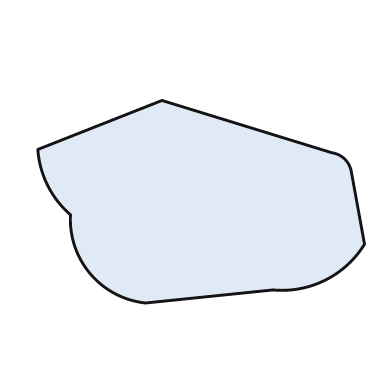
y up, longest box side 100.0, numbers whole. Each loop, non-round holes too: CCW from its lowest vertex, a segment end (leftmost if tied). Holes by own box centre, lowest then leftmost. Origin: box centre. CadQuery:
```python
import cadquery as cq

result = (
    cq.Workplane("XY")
    .moveTo(-17.0, -31.0)
    .lineTo(22.0, -27.0)
    .threePointArc((38.0, -24.0), (50.0, -13.0))
    .lineTo(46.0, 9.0)
    .threePointArc((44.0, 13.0), (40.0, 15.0))
    .lineTo(-12.0, 31.0)
    .lineTo(-50.0, 16.0)
    .threePointArc((-47.0, 5.0), (-40.0, -4.0))
    .threePointArc((-34.0, -22.0), (-17.0, -31.0))
    .close()
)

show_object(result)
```